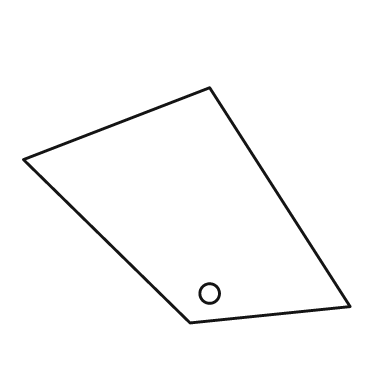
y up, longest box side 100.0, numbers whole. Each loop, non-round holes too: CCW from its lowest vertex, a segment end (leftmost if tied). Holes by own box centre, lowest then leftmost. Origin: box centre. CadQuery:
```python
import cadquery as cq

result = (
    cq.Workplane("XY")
    .moveTo(1.0, -36.0)
    .lineTo(50.0, -31.0)
    .lineTo(7.0, 36.0)
    .lineTo(-50.0, 14.0)
    .close()
    .moveTo(7.0, -27.0)
    .circle(3.0)
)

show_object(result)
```